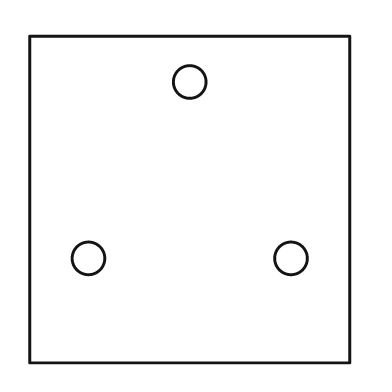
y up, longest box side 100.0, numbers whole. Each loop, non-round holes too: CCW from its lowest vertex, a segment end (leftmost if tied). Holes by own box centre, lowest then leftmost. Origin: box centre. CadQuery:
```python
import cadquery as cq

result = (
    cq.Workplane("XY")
    .moveTo(-49.0, -50.0)
    .lineTo(49.0, -50.0)
    .lineTo(49.0, 50.0)
    .lineTo(-49.0, 50.0)
    .close()
    .moveTo(-31.0, -18.0)
    .circle(5.0)
    .moveTo(31.0, -18.0)
    .circle(5.0)
    .moveTo(0.0, 36.0)
    .circle(5.0)
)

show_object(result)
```